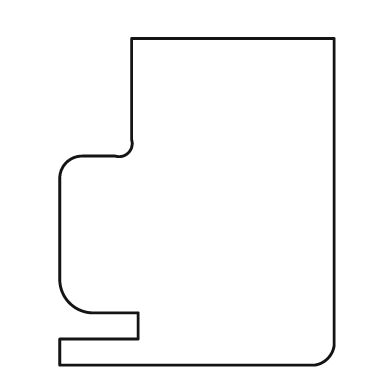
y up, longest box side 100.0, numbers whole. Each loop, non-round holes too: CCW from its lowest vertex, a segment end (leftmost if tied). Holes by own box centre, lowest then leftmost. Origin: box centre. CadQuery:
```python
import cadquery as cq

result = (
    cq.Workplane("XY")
    .moveTo(-42.0, -50.0)
    .lineTo(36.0, -50.0)
    .threePointArc((40.0, -48.0), (42.0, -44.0))
    .lineTo(42.0, 50.0)
    .lineTo(-20.0, 50.0)
    .lineTo(-20.0, 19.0)
    .threePointArc((-21.0, 15.0), (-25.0, 14.0))
    .lineTo(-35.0, 14.0)
    .threePointArc((-40.0, 12.0), (-42.0, 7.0))
    .lineTo(-42.0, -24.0)
    .threePointArc((-39.0, -31.0), (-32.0, -34.0))
    .lineTo(-18.0, -34.0)
    .lineTo(-18.0, -42.0)
    .lineTo(-42.0, -42.0)
    .close()
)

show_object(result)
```